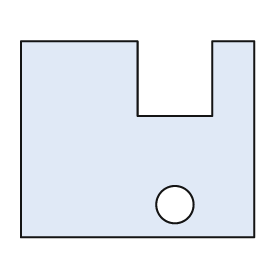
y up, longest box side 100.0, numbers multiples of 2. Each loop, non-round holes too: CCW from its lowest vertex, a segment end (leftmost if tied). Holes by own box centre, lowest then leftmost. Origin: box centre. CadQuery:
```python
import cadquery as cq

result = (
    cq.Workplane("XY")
    .moveTo(-50.0, -42.0)
    .lineTo(50.0, -42.0)
    .lineTo(50.0, 42.0)
    .lineTo(32.0, 42.0)
    .lineTo(32.0, 10.0)
    .lineTo(0.0, 10.0)
    .lineTo(0.0, 42.0)
    .lineTo(-50.0, 42.0)
    .close()
    .moveTo(16.0, -28.0)
    .circle(8.0)
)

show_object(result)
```